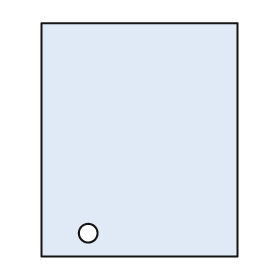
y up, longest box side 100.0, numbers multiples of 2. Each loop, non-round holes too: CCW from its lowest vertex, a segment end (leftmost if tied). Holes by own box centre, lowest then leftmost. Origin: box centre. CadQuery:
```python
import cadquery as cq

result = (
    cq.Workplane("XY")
    .moveTo(-42.0, -50.0)
    .lineTo(42.0, -50.0)
    .lineTo(42.0, 50.0)
    .lineTo(-42.0, 50.0)
    .close()
    .moveTo(-22.0, -40.0)
    .circle(4.0)
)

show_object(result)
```